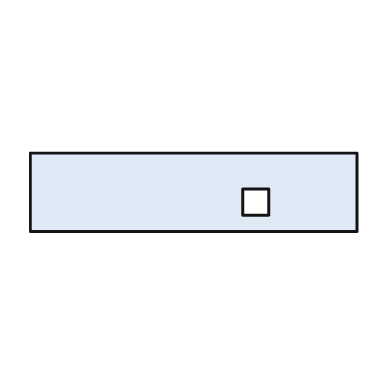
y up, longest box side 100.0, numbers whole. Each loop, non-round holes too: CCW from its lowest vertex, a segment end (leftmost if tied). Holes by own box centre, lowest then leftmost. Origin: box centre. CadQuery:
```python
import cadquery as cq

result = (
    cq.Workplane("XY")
    .moveTo(-50.0, -12.0)
    .lineTo(50.0, -12.0)
    .lineTo(50.0, 12.0)
    .lineTo(-50.0, 12.0)
    .close()
    .moveTo(15.0, -7.0)
    .lineTo(23.0, -7.0)
    .lineTo(23.0, 1.0)
    .lineTo(15.0, 1.0)
    .close()
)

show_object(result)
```